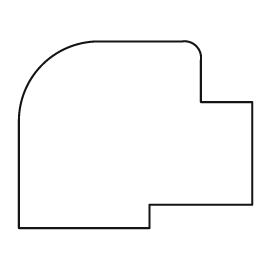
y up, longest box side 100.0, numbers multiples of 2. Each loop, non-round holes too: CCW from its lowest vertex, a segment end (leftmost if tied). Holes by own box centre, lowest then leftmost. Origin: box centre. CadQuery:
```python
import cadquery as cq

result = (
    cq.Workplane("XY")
    .moveTo(-50.0, -40.0)
    .lineTo(6.0, -40.0)
    .lineTo(6.0, -30.0)
    .lineTo(50.0, -30.0)
    .lineTo(50.0, 14.0)
    .lineTo(28.0, 14.0)
    .lineTo(28.0, 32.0)
    .threePointArc((26.0, 38.0), (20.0, 40.0))
    .lineTo(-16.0, 40.0)
    .threePointArc((-40.0, 30.0), (-50.0, 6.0))
    .close()
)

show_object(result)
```